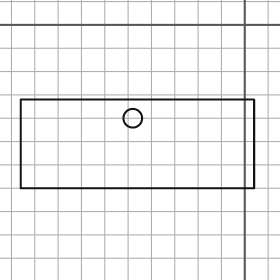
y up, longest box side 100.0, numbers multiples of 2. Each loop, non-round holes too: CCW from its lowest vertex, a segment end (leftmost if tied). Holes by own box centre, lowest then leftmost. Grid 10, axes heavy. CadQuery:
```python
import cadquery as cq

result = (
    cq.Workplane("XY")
    .moveTo(-96.0, -70.0)
    .lineTo(4.0, -70.0)
    .lineTo(4.0, -32.0)
    .lineTo(-96.0, -32.0)
    .close()
    .moveTo(-48.0, -40.0)
    .circle(4.0)
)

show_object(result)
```